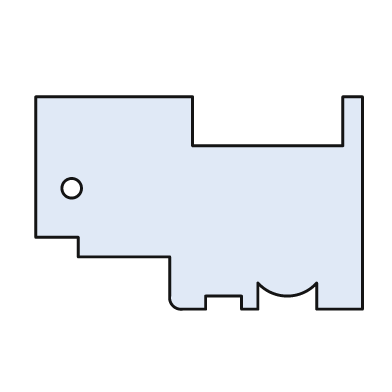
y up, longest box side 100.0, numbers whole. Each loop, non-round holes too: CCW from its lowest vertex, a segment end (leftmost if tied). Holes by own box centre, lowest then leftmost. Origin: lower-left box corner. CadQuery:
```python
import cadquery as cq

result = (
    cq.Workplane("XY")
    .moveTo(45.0, 0.0)
    .lineTo(52.0, 0.0)
    .lineTo(52.0, 4.0)
    .lineTo(63.0, 4.0)
    .lineTo(63.0, 0.0)
    .lineTo(68.0, 0.0)
    .lineTo(68.0, 8.0)
    .threePointArc((77.0, 4.0), (86.0, 8.0))
    .lineTo(86.0, 0.0)
    .lineTo(100.0, 0.0)
    .lineTo(100.0, 65.0)
    .lineTo(94.0, 65.0)
    .lineTo(94.0, 50.0)
    .lineTo(48.0, 50.0)
    .lineTo(48.0, 65.0)
    .lineTo(0.0, 65.0)
    .lineTo(0.0, 22.0)
    .lineTo(13.0, 22.0)
    .lineTo(13.0, 16.0)
    .lineTo(41.0, 16.0)
    .lineTo(41.0, 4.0)
    .threePointArc((42.0, 1.0), (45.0, 0.0))
    .close()
    .moveTo(11.0, 37.0)
    .circle(3.0)
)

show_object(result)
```